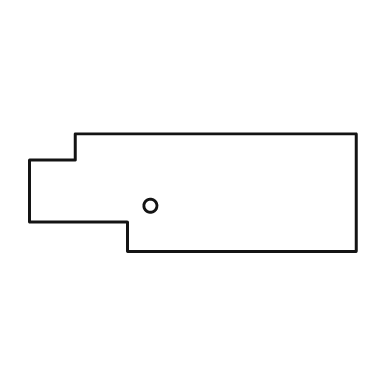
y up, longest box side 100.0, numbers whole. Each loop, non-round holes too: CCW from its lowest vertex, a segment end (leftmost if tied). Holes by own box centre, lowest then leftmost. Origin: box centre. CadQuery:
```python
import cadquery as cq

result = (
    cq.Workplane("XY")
    .moveTo(-20.0, -18.0)
    .lineTo(50.0, -18.0)
    .lineTo(50.0, 18.0)
    .lineTo(-36.0, 18.0)
    .lineTo(-36.0, 10.0)
    .lineTo(-50.0, 10.0)
    .lineTo(-50.0, -9.0)
    .lineTo(-20.0, -9.0)
    .close()
    .moveTo(-13.0, -4.0)
    .circle(2.0)
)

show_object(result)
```